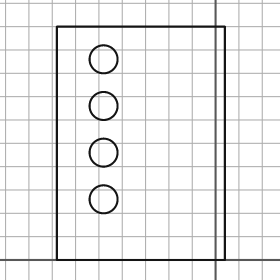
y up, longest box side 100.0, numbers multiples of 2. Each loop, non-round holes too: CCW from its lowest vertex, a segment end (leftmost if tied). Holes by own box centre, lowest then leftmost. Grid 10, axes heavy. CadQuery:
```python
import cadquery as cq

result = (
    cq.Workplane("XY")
    .moveTo(-68.0, 0.0)
    .lineTo(4.0, 0.0)
    .lineTo(4.0, 100.0)
    .lineTo(-68.0, 100.0)
    .close()
    .moveTo(-48.0, 26.0)
    .circle(6.0)
    .moveTo(-48.0, 46.0)
    .circle(6.0)
    .moveTo(-48.0, 66.0)
    .circle(6.0)
    .moveTo(-48.0, 86.0)
    .circle(6.0)
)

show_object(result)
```